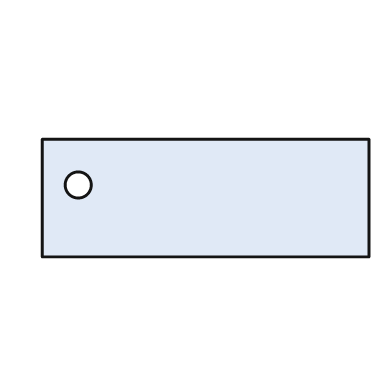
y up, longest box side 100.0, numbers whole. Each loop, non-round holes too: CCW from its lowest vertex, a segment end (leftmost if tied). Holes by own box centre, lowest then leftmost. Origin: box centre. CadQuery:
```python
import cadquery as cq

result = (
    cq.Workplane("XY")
    .moveTo(-50.0, -18.0)
    .lineTo(50.0, -18.0)
    .lineTo(50.0, 18.0)
    .lineTo(-50.0, 18.0)
    .close()
    .moveTo(-39.0, 4.0)
    .circle(4.0)
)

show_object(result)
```